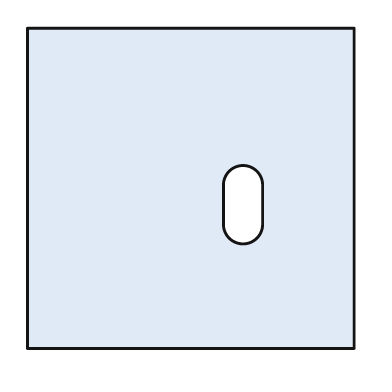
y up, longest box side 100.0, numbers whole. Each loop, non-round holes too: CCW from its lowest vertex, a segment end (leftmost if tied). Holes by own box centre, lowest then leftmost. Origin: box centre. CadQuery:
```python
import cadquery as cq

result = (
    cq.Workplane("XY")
    .moveTo(-50.0, -49.0)
    .lineTo(50.0, -49.0)
    .lineTo(50.0, 49.0)
    .lineTo(-50.0, 49.0)
    .close()
    .moveTo(10.0, -11.0)
    .threePointArc((16.0, -17.0), (22.0, -11.0))
    .lineTo(22.0, 1.0)
    .threePointArc((16.0, 7.0), (10.0, 1.0))
    .close()
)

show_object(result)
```